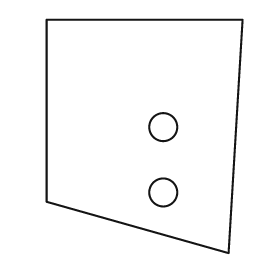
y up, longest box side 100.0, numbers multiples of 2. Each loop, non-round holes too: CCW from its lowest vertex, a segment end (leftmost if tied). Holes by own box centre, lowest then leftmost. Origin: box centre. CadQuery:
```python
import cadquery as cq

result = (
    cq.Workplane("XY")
    .moveTo(36.0, -50.0)
    .lineTo(42.0, 50.0)
    .lineTo(-42.0, 50.0)
    .lineTo(-42.0, -28.0)
    .close()
    .moveTo(8.0, -24.0)
    .circle(6.0)
    .moveTo(8.0, 4.0)
    .circle(6.0)
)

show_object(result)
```